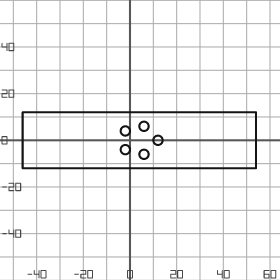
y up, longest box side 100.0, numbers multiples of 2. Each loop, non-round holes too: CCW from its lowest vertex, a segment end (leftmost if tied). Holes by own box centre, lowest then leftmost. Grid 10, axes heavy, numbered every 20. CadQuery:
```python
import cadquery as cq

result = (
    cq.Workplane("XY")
    .moveTo(-46.0, -12.0)
    .lineTo(54.0, -12.0)
    .lineTo(54.0, 12.0)
    .lineTo(-46.0, 12.0)
    .close()
    .moveTo(6.0, -6.0)
    .circle(2.0)
    .moveTo(-2.0, -4.0)
    .circle(2.0)
    .moveTo(12.0, 0.0)
    .circle(2.0)
    .moveTo(-2.0, 4.0)
    .circle(2.0)
    .moveTo(6.0, 6.0)
    .circle(2.0)
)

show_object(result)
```